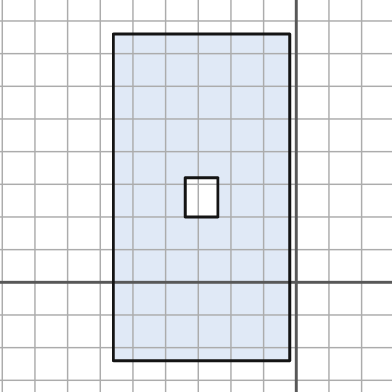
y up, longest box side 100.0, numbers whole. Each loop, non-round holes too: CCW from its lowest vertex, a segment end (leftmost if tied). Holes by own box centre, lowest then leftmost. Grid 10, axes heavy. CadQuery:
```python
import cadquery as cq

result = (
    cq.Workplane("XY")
    .moveTo(-56.0, -24.0)
    .lineTo(-2.0, -24.0)
    .lineTo(-2.0, 76.0)
    .lineTo(-56.0, 76.0)
    .close()
    .moveTo(-34.0, 20.0)
    .lineTo(-24.0, 20.0)
    .lineTo(-24.0, 32.0)
    .lineTo(-34.0, 32.0)
    .close()
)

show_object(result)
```